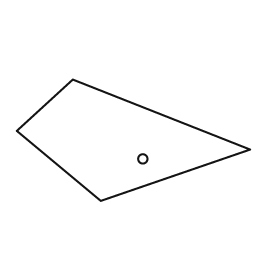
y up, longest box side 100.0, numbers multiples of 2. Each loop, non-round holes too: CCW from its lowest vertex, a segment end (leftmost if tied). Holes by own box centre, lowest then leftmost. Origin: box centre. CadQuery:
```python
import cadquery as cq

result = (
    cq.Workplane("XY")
    .moveTo(-14.0, -26.0)
    .lineTo(50.0, -4.0)
    .lineTo(-26.0, 26.0)
    .lineTo(-50.0, 4.0)
    .close()
    .moveTo(4.0, -8.0)
    .circle(2.0)
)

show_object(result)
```